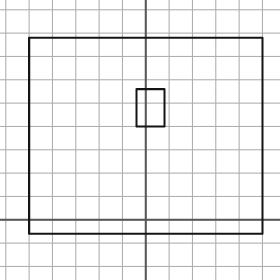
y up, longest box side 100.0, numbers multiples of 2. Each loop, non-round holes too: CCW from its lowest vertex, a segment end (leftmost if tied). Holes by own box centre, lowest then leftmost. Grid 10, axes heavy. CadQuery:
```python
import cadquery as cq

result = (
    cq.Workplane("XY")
    .moveTo(-50.0, -6.0)
    .lineTo(50.0, -6.0)
    .lineTo(50.0, 78.0)
    .lineTo(-50.0, 78.0)
    .close()
    .moveTo(-4.0, 40.0)
    .lineTo(8.0, 40.0)
    .lineTo(8.0, 56.0)
    .lineTo(-4.0, 56.0)
    .close()
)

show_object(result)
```